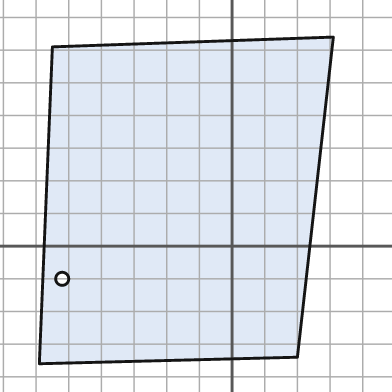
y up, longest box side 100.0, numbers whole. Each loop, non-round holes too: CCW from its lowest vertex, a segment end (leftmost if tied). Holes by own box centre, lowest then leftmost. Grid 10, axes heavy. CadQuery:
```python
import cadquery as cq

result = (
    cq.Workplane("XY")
    .moveTo(-59.0, -36.0)
    .lineTo(20.0, -34.0)
    .lineTo(31.0, 64.0)
    .lineTo(-55.0, 61.0)
    .close()
    .moveTo(-52.0, -10.0)
    .circle(2.0)
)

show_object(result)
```